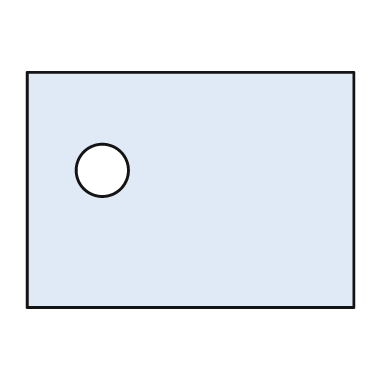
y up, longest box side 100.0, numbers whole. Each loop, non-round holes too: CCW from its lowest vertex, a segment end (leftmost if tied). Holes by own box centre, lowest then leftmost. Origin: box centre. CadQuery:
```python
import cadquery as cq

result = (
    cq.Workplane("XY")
    .moveTo(-50.0, -36.0)
    .lineTo(50.0, -36.0)
    .lineTo(50.0, 36.0)
    .lineTo(-50.0, 36.0)
    .close()
    .moveTo(-27.0, 6.0)
    .circle(8.0)
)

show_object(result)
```